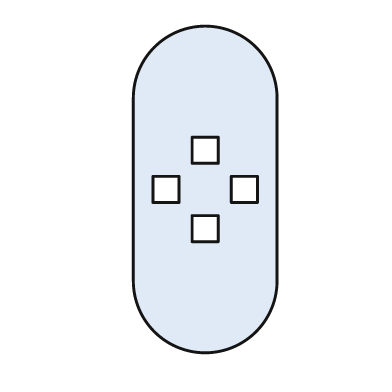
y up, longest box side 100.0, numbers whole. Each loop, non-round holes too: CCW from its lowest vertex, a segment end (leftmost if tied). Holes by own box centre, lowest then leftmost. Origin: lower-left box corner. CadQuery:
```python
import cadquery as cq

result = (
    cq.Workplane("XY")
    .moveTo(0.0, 22.0)
    .threePointArc((22.0, 0.0), (44.0, 22.0))
    .lineTo(44.0, 78.0)
    .threePointArc((22.0, 100.0), (0.0, 78.0))
    .close()
    .moveTo(18.0, 34.0)
    .lineTo(26.0, 34.0)
    .lineTo(26.0, 42.0)
    .lineTo(18.0, 42.0)
    .close()
    .moveTo(6.0, 46.0)
    .lineTo(14.0, 46.0)
    .lineTo(14.0, 54.0)
    .lineTo(6.0, 54.0)
    .close()
    .moveTo(30.0, 46.0)
    .lineTo(38.0, 46.0)
    .lineTo(38.0, 54.0)
    .lineTo(30.0, 54.0)
    .close()
    .moveTo(18.0, 58.0)
    .lineTo(26.0, 58.0)
    .lineTo(26.0, 66.0)
    .lineTo(18.0, 66.0)
    .close()
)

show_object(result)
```